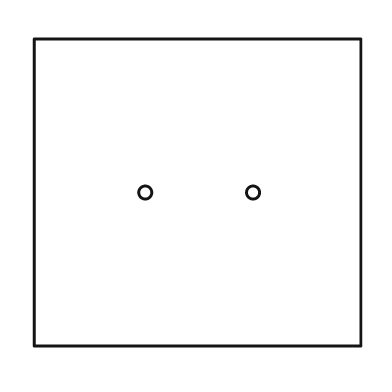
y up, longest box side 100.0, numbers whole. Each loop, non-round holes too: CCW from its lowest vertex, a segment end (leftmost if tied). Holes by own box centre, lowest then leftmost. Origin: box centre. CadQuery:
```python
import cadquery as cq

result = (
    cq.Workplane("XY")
    .moveTo(-50.0, -47.0)
    .lineTo(50.0, -47.0)
    .lineTo(50.0, 47.0)
    .lineTo(-50.0, 47.0)
    .close()
    .moveTo(-16.0, 0.0)
    .circle(2.0)
    .moveTo(17.0, 0.0)
    .circle(2.0)
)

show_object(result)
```